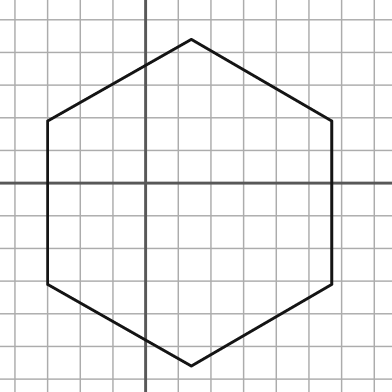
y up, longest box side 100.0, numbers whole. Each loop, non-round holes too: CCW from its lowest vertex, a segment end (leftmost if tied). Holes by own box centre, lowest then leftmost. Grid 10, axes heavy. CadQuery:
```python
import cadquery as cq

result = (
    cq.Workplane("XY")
    .moveTo(14.0, -56.0)
    .lineTo(57.0, -31.0)
    .lineTo(57.0, 19.0)
    .lineTo(14.0, 44.0)
    .lineTo(-30.0, 19.0)
    .lineTo(-30.0, -31.0)
    .close()
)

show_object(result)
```